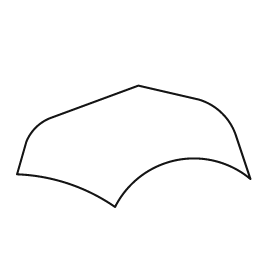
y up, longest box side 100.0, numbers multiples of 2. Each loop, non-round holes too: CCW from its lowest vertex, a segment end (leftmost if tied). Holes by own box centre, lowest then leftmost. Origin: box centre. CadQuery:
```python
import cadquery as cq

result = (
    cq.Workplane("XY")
    .moveTo(-8.0, -26.0)
    .threePointArc((18.0, -6.0), (50.0, -14.0))
    .lineTo(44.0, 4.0)
    .threePointArc((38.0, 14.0), (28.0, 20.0))
    .lineTo(2.0, 26.0)
    .lineTo(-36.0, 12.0)
    .threePointArc((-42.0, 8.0), (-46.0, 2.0))
    .lineTo(-50.0, -12.0)
    .threePointArc((-28.0, -16.0), (-8.0, -26.0))
    .close()
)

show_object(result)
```